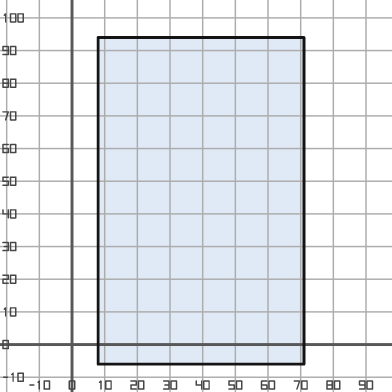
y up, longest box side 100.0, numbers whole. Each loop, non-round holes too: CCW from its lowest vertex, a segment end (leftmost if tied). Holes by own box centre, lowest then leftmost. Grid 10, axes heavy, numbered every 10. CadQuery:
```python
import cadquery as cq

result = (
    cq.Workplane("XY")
    .moveTo(8.0, -6.0)
    .lineTo(71.0, -6.0)
    .lineTo(71.0, 94.0)
    .lineTo(8.0, 94.0)
    .close()
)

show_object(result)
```